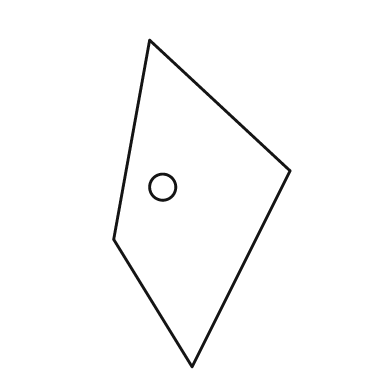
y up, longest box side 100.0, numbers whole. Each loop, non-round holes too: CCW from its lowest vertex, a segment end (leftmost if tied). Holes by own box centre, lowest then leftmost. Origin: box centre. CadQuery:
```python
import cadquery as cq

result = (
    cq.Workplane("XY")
    .moveTo(-3.0, -50.0)
    .lineTo(27.0, 10.0)
    .lineTo(-16.0, 50.0)
    .lineTo(-27.0, -11.0)
    .close()
    .moveTo(-12.0, 5.0)
    .circle(4.0)
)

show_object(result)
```